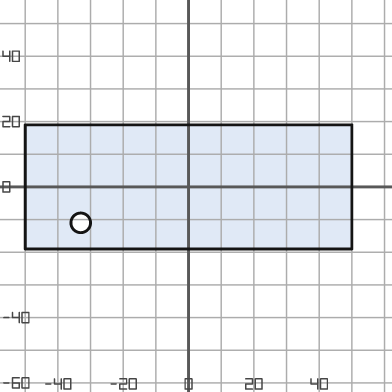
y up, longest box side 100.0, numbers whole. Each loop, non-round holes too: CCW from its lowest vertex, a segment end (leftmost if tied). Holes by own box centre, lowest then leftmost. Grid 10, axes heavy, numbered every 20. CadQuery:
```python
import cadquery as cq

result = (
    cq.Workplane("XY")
    .moveTo(-50.0, -19.0)
    .lineTo(50.0, -19.0)
    .lineTo(50.0, 19.0)
    .lineTo(-50.0, 19.0)
    .close()
    .moveTo(-33.0, -11.0)
    .circle(3.0)
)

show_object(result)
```